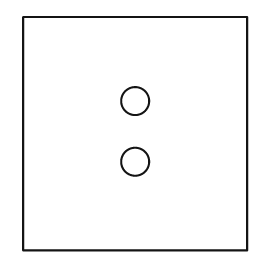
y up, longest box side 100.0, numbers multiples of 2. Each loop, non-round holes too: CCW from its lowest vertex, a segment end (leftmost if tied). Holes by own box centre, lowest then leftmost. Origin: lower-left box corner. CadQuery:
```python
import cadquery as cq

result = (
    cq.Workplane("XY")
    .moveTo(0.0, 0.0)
    .lineTo(96.0, 0.0)
    .lineTo(96.0, 100.0)
    .lineTo(0.0, 100.0)
    .close()
    .moveTo(48.0, 38.0)
    .circle(6.0)
    .moveTo(48.0, 64.0)
    .circle(6.0)
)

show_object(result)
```